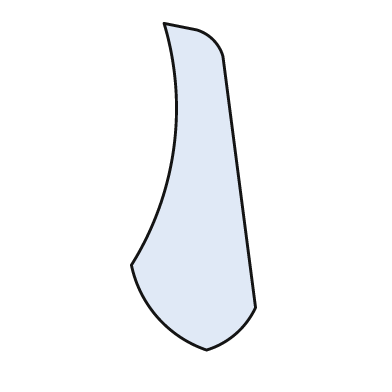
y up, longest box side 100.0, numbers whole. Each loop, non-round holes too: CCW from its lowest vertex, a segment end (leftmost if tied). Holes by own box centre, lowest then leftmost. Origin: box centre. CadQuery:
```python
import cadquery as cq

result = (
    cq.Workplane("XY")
    .moveTo(4.0, -50.0)
    .threePointArc((13.0, -45.0), (19.0, -37.0))
    .lineTo(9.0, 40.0)
    .threePointArc((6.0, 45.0), (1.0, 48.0))
    .lineTo(-9.0, 50.0)
    .threePointArc((-6.0, 12.0), (-19.0, -24.0))
    .threePointArc((-11.0, -40.0), (4.0, -50.0))
    .close()
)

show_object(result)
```